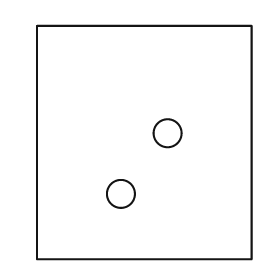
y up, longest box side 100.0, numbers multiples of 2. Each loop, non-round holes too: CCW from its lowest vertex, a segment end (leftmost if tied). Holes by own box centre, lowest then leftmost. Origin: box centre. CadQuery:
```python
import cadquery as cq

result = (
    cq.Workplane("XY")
    .moveTo(-46.0, -50.0)
    .lineTo(46.0, -50.0)
    .lineTo(46.0, 50.0)
    .lineTo(-46.0, 50.0)
    .close()
    .moveTo(-10.0, -22.0)
    .circle(6.0)
    .moveTo(10.0, 4.0)
    .circle(6.0)
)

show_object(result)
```